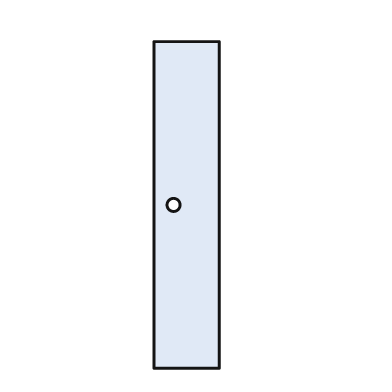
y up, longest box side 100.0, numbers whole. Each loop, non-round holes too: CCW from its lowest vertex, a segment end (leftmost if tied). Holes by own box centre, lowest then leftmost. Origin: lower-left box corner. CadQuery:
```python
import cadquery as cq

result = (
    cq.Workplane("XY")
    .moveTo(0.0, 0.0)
    .lineTo(20.0, 0.0)
    .lineTo(20.0, 100.0)
    .lineTo(0.0, 100.0)
    .close()
    .moveTo(6.0, 50.0)
    .circle(2.0)
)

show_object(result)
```